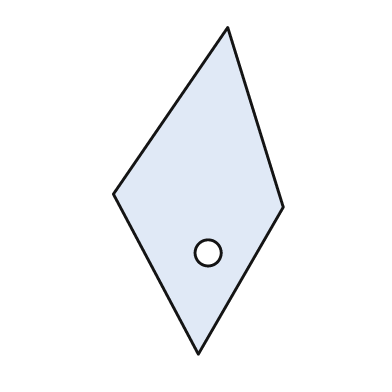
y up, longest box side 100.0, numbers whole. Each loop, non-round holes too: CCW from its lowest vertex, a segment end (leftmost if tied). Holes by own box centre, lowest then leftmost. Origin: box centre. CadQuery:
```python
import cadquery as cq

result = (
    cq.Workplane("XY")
    .moveTo(0.0, -50.0)
    .lineTo(26.0, -5.0)
    .lineTo(9.0, 50.0)
    .lineTo(-26.0, -1.0)
    .close()
    .moveTo(3.0, -19.0)
    .circle(4.0)
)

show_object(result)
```